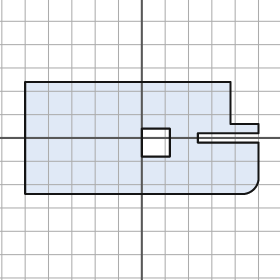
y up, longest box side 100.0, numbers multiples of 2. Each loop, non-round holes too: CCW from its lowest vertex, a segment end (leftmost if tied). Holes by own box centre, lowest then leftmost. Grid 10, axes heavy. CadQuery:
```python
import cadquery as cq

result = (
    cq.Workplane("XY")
    .moveTo(-50.0, -24.0)
    .lineTo(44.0, -24.0)
    .threePointArc((48.0, -22.0), (50.0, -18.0))
    .lineTo(50.0, -2.0)
    .lineTo(24.0, -2.0)
    .lineTo(24.0, 2.0)
    .lineTo(50.0, 2.0)
    .lineTo(50.0, 6.0)
    .lineTo(38.0, 6.0)
    .lineTo(38.0, 24.0)
    .lineTo(-50.0, 24.0)
    .close()
    .moveTo(0.0, -8.0)
    .lineTo(12.0, -8.0)
    .lineTo(12.0, 4.0)
    .lineTo(0.0, 4.0)
    .close()
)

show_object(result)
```